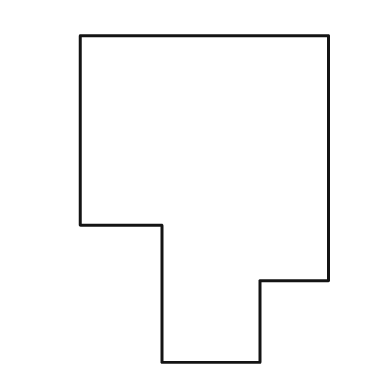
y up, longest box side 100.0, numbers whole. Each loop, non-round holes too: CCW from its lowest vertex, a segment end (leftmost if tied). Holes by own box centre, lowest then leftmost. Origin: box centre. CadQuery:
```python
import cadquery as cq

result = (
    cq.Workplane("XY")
    .moveTo(-13.0, -50.0)
    .lineTo(17.0, -50.0)
    .lineTo(17.0, -25.0)
    .lineTo(38.0, -25.0)
    .lineTo(38.0, 50.0)
    .lineTo(-38.0, 50.0)
    .lineTo(-38.0, -8.0)
    .lineTo(-13.0, -8.0)
    .close()
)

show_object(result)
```